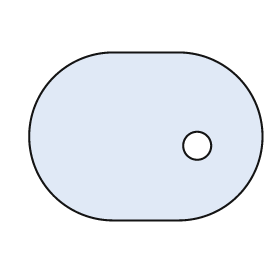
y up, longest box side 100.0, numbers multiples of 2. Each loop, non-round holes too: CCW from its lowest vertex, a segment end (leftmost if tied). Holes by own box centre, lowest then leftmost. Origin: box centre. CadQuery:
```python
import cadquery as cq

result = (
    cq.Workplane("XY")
    .moveTo(-14.0, -36.0)
    .lineTo(14.0, -36.0)
    .threePointArc((50.0, 0.0), (14.0, 36.0))
    .lineTo(-14.0, 36.0)
    .threePointArc((-50.0, 0.0), (-14.0, -36.0))
    .close()
    .moveTo(22.0, -4.0)
    .circle(6.0)
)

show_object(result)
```